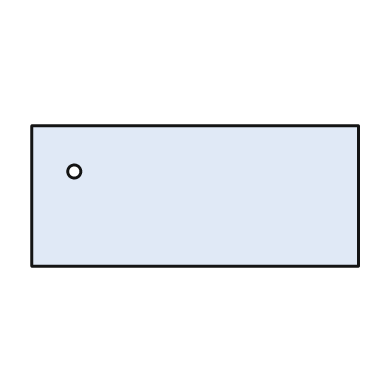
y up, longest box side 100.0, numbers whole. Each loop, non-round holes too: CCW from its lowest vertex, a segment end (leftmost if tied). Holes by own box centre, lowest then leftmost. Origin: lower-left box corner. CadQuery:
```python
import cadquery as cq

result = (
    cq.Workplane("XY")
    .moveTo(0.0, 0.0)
    .lineTo(100.0, 0.0)
    .lineTo(100.0, 43.0)
    .lineTo(0.0, 43.0)
    .close()
    .moveTo(13.0, 29.0)
    .circle(2.0)
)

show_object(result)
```